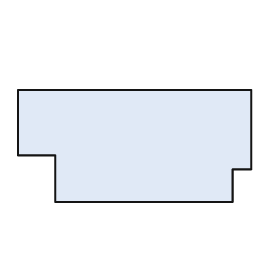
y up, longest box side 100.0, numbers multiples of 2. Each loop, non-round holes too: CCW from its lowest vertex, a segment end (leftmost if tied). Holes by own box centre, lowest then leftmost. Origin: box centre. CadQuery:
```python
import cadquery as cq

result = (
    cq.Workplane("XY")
    .moveTo(-34.0, -24.0)
    .lineTo(42.0, -24.0)
    .lineTo(42.0, -10.0)
    .lineTo(50.0, -10.0)
    .lineTo(50.0, 24.0)
    .lineTo(-50.0, 24.0)
    .lineTo(-50.0, -4.0)
    .lineTo(-34.0, -4.0)
    .close()
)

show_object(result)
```